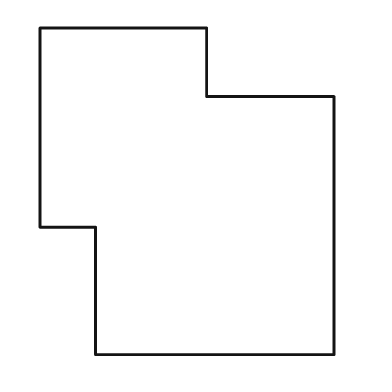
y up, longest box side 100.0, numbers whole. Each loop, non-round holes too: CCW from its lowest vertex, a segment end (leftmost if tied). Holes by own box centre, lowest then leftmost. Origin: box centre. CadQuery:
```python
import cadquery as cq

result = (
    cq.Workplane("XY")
    .moveTo(-28.0, -50.0)
    .lineTo(45.0, -50.0)
    .lineTo(45.0, 29.0)
    .lineTo(6.0, 29.0)
    .lineTo(6.0, 50.0)
    .lineTo(-45.0, 50.0)
    .lineTo(-45.0, -11.0)
    .lineTo(-28.0, -11.0)
    .close()
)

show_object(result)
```